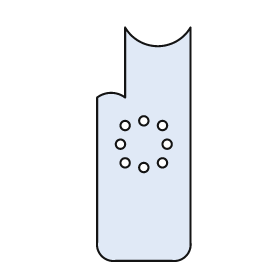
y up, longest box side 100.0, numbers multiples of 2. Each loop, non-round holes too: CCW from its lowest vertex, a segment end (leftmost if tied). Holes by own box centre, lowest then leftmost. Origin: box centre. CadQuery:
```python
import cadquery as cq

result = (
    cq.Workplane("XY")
    .moveTo(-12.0, -50.0)
    .lineTo(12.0, -50.0)
    .threePointArc((18.0, -48.0), (20.0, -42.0))
    .lineTo(20.0, 50.0)
    .threePointArc((6.0, 42.0), (-8.0, 50.0))
    .lineTo(-8.0, 20.0)
    .threePointArc((-14.0, 22.0), (-20.0, 20.0))
    .lineTo(-20.0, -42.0)
    .threePointArc((-18.0, -48.0), (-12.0, -50.0))
    .close()
    .moveTo(0.0, -10.0)
    .circle(2.0)
    .moveTo(-8.0, -8.0)
    .circle(2.0)
    .moveTo(8.0, -8.0)
    .circle(2.0)
    .moveTo(-10.0, 0.0)
    .circle(2.0)
    .moveTo(10.0, 0.0)
    .circle(2.0)
    .moveTo(-8.0, 8.0)
    .circle(2.0)
    .moveTo(8.0, 8.0)
    .circle(2.0)
    .moveTo(0.0, 10.0)
    .circle(2.0)
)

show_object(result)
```